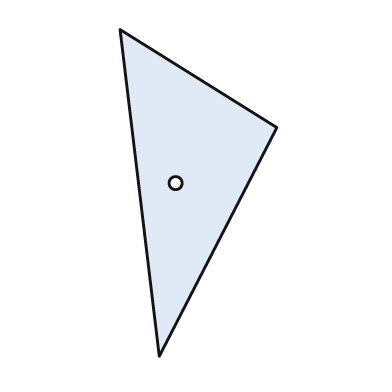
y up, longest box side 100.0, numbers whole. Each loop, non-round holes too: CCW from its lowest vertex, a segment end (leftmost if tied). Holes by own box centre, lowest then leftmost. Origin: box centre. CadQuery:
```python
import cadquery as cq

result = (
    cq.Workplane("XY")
    .moveTo(-12.0, -50.0)
    .lineTo(24.0, 20.0)
    .lineTo(-24.0, 50.0)
    .close()
    .moveTo(-7.0, 3.0)
    .circle(2.0)
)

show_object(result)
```